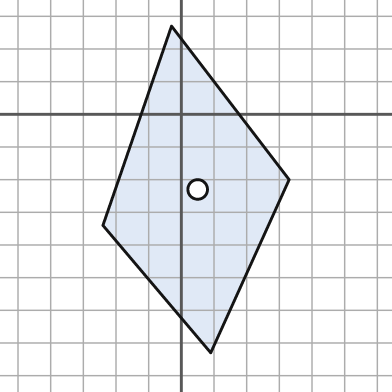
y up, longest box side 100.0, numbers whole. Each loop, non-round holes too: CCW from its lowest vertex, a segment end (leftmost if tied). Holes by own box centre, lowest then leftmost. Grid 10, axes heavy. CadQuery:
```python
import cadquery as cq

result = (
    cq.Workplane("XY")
    .moveTo(9.0, -73.0)
    .lineTo(33.0, -20.0)
    .lineTo(-3.0, 27.0)
    .lineTo(-24.0, -34.0)
    .close()
    .moveTo(5.0, -23.0)
    .circle(3.0)
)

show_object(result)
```